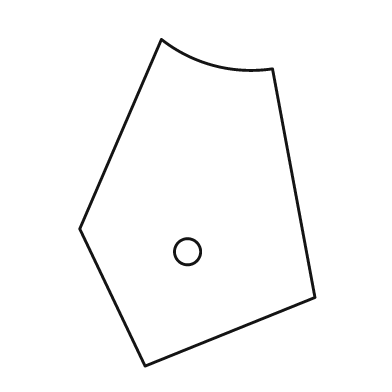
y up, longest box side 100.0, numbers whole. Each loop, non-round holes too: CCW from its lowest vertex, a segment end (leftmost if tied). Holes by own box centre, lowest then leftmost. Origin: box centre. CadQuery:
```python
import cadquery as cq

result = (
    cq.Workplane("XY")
    .moveTo(-16.0, -50.0)
    .lineTo(36.0, -29.0)
    .lineTo(23.0, 41.0)
    .threePointArc((5.0, 42.0), (-11.0, 50.0))
    .lineTo(-36.0, -8.0)
    .close()
    .moveTo(-3.0, -15.0)
    .circle(4.0)
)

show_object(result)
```